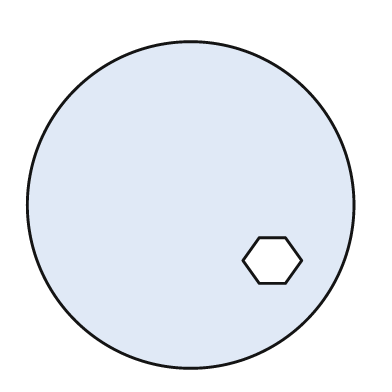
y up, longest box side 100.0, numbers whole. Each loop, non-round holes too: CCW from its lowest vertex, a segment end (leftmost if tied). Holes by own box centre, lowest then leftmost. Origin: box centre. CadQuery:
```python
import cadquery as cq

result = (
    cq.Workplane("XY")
    .moveTo(0.0, 0.0)
    .circle(50.0)
    .moveTo(21.0, -24.0)
    .lineTo(29.0, -24.0)
    .lineTo(34.0, -17.0)
    .lineTo(29.0, -10.0)
    .lineTo(21.0, -10.0)
    .lineTo(16.0, -17.0)
    .close()
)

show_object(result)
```